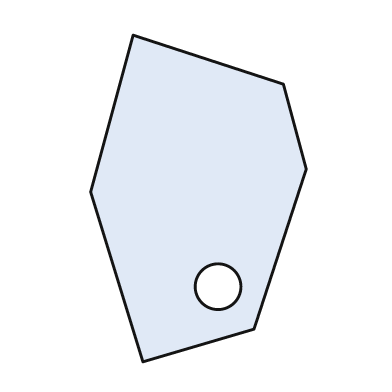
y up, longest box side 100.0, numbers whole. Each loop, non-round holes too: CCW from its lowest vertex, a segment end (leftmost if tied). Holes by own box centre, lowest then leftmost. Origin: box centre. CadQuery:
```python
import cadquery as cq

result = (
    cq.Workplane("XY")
    .moveTo(-17.0, -50.0)
    .lineTo(17.0, -40.0)
    .lineTo(33.0, 9.0)
    .lineTo(26.0, 35.0)
    .lineTo(-20.0, 50.0)
    .lineTo(-33.0, 2.0)
    .close()
    .moveTo(6.0, -27.0)
    .circle(7.0)
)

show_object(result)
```